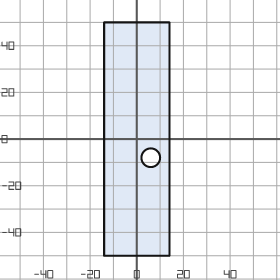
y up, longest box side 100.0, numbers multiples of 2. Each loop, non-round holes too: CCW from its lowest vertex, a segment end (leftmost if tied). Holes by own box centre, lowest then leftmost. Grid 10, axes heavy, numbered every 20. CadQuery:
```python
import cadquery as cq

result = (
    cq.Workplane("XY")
    .moveTo(-14.0, -50.0)
    .lineTo(14.0, -50.0)
    .lineTo(14.0, 50.0)
    .lineTo(-14.0, 50.0)
    .close()
    .moveTo(6.0, -8.0)
    .circle(4.0)
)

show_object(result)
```